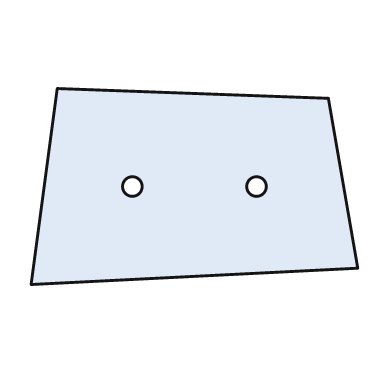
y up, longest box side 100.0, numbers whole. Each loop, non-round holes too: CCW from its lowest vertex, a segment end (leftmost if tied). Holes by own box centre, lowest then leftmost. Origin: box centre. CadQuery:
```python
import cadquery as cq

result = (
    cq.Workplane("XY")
    .moveTo(-50.0, -30.0)
    .lineTo(50.0, -25.0)
    .lineTo(41.0, 27.0)
    .lineTo(-42.0, 30.0)
    .close()
    .moveTo(-19.0, 0.0)
    .circle(3.0)
    .moveTo(19.0, 0.0)
    .circle(3.0)
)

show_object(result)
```